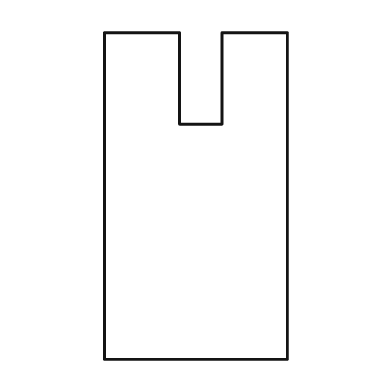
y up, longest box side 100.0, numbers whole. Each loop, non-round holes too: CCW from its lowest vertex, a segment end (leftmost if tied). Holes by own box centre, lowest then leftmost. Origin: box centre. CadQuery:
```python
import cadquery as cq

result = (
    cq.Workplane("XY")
    .moveTo(-28.0, -50.0)
    .lineTo(28.0, -50.0)
    .lineTo(28.0, 50.0)
    .lineTo(8.0, 50.0)
    .lineTo(8.0, 22.0)
    .lineTo(-5.0, 22.0)
    .lineTo(-5.0, 50.0)
    .lineTo(-28.0, 50.0)
    .close()
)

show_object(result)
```